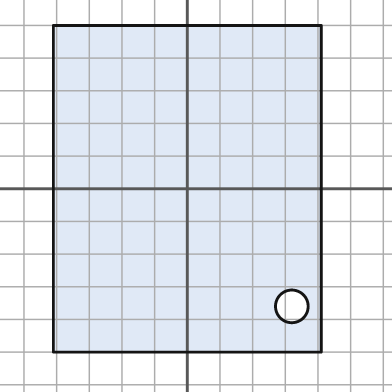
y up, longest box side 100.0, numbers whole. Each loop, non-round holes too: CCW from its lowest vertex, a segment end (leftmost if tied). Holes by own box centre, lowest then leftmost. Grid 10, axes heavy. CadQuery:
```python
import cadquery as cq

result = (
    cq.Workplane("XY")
    .moveTo(-41.0, -50.0)
    .lineTo(41.0, -50.0)
    .lineTo(41.0, 50.0)
    .lineTo(-41.0, 50.0)
    .close()
    .moveTo(32.0, -36.0)
    .circle(5.0)
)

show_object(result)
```